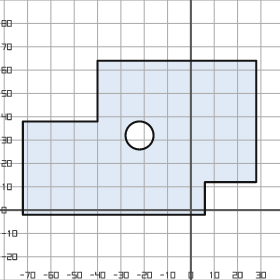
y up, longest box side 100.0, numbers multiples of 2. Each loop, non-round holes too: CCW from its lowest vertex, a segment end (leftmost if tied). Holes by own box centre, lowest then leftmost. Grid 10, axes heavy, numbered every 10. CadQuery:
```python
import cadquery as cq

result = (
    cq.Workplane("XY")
    .moveTo(-72.0, -2.0)
    .lineTo(6.0, -2.0)
    .lineTo(6.0, 12.0)
    .lineTo(28.0, 12.0)
    .lineTo(28.0, 64.0)
    .lineTo(-40.0, 64.0)
    .lineTo(-40.0, 38.0)
    .lineTo(-72.0, 38.0)
    .close()
    .moveTo(-22.0, 32.0)
    .circle(6.0)
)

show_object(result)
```